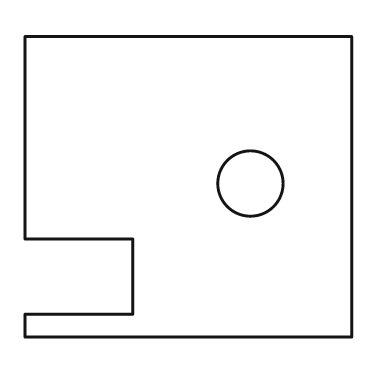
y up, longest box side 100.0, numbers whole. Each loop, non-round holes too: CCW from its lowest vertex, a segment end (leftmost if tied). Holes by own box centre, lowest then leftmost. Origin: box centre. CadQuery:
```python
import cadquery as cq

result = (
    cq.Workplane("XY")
    .moveTo(-50.0, -46.0)
    .lineTo(50.0, -46.0)
    .lineTo(50.0, 46.0)
    .lineTo(-50.0, 46.0)
    .lineTo(-50.0, -16.0)
    .lineTo(-17.0, -16.0)
    .lineTo(-17.0, -39.0)
    .lineTo(-50.0, -39.0)
    .close()
    .moveTo(19.0, 1.0)
    .circle(10.0)
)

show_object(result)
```